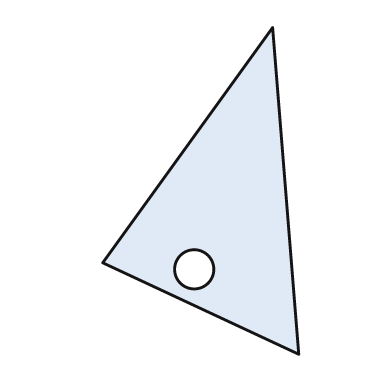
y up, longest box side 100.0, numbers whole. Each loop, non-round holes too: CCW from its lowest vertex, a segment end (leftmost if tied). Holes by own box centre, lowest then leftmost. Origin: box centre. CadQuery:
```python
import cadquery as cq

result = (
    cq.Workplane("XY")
    .moveTo(30.0, -50.0)
    .lineTo(22.0, 50.0)
    .lineTo(-30.0, -22.0)
    .close()
    .moveTo(-2.0, -24.0)
    .circle(6.0)
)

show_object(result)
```